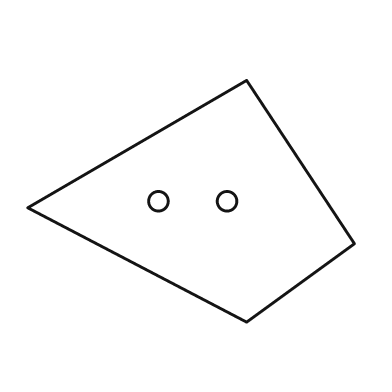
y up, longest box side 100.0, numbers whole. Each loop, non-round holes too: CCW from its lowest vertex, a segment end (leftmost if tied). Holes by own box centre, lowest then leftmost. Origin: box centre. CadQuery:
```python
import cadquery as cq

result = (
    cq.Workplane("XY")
    .moveTo(17.0, -37.0)
    .lineTo(50.0, -13.0)
    .lineTo(17.0, 37.0)
    .lineTo(-50.0, -2.0)
    .close()
    .moveTo(-10.0, 0.0)
    .circle(3.0)
    .moveTo(11.0, 0.0)
    .circle(3.0)
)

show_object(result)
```